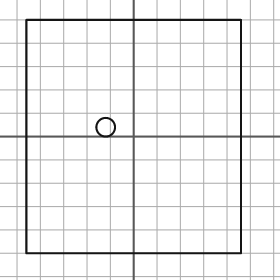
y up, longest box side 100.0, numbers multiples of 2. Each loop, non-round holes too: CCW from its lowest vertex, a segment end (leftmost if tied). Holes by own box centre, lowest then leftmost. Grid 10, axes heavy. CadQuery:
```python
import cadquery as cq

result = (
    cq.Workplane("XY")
    .moveTo(-46.0, -50.0)
    .lineTo(46.0, -50.0)
    .lineTo(46.0, 50.0)
    .lineTo(-46.0, 50.0)
    .close()
    .moveTo(-12.0, 4.0)
    .circle(4.0)
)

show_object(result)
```